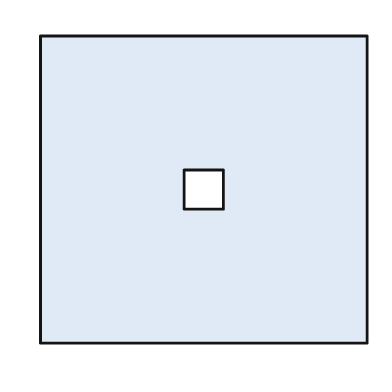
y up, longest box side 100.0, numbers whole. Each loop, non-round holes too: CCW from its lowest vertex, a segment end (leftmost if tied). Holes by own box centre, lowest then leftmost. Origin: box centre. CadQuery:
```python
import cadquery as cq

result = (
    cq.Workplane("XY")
    .moveTo(-50.0, -47.0)
    .lineTo(50.0, -47.0)
    .lineTo(50.0, 47.0)
    .lineTo(-50.0, 47.0)
    .close()
    .moveTo(-6.0, -6.0)
    .lineTo(6.0, -6.0)
    .lineTo(6.0, 6.0)
    .lineTo(-6.0, 6.0)
    .close()
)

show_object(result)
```